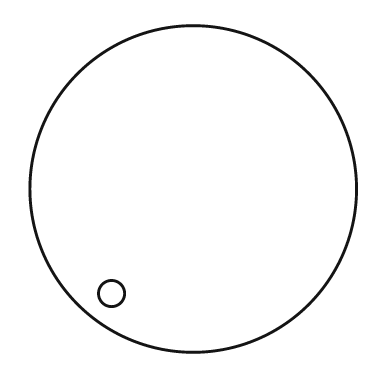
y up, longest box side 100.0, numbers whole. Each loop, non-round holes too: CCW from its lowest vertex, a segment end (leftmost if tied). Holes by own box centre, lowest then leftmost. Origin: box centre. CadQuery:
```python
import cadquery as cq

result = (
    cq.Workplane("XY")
    .moveTo(0.0, 0.0)
    .circle(50.0)
    .moveTo(-25.0, -32.0)
    .circle(4.0)
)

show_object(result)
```